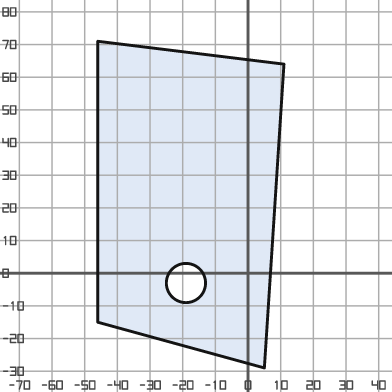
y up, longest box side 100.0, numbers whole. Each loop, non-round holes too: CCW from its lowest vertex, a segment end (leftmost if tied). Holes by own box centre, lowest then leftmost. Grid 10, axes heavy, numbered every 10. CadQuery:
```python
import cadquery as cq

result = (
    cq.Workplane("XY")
    .moveTo(5.0, -29.0)
    .lineTo(11.0, 64.0)
    .lineTo(-46.0, 71.0)
    .lineTo(-46.0, -15.0)
    .close()
    .moveTo(-19.0, -3.0)
    .circle(6.0)
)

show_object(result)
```